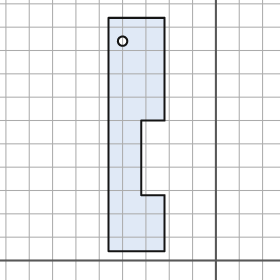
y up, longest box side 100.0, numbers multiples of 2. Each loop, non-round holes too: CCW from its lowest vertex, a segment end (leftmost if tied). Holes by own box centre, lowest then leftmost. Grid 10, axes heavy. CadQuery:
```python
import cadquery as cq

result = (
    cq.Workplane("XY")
    .moveTo(-46.0, 4.0)
    .lineTo(-22.0, 4.0)
    .lineTo(-22.0, 28.0)
    .lineTo(-32.0, 28.0)
    .lineTo(-32.0, 60.0)
    .lineTo(-22.0, 60.0)
    .lineTo(-22.0, 104.0)
    .lineTo(-46.0, 104.0)
    .close()
    .moveTo(-40.0, 94.0)
    .circle(2.0)
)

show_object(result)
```